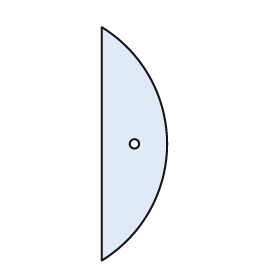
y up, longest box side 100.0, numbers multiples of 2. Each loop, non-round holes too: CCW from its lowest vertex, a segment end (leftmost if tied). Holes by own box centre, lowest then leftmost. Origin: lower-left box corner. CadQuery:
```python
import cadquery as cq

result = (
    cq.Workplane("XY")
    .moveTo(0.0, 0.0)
    .threePointArc((28.0, 50.0), (0.0, 100.0))
    .close()
    .moveTo(14.0, 50.0)
    .circle(2.0)
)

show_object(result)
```